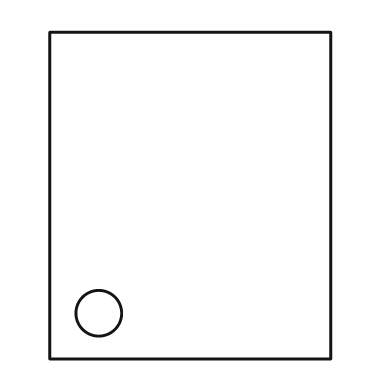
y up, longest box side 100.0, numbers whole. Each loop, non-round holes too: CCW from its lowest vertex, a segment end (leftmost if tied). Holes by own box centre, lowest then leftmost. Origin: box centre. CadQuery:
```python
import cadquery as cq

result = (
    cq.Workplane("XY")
    .moveTo(-43.0, -50.0)
    .lineTo(43.0, -50.0)
    .lineTo(43.0, 50.0)
    .lineTo(-43.0, 50.0)
    .close()
    .moveTo(-28.0, -36.0)
    .circle(7.0)
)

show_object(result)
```